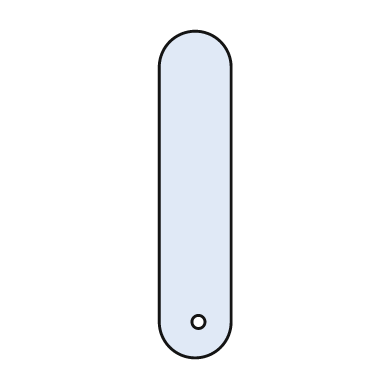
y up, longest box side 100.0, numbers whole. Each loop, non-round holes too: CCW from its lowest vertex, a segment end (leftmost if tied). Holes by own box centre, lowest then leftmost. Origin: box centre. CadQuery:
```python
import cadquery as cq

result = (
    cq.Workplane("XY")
    .moveTo(-11.0, -39.0)
    .threePointArc((0.0, -50.0), (11.0, -39.0))
    .lineTo(11.0, 39.0)
    .threePointArc((0.0, 50.0), (-11.0, 39.0))
    .close()
    .moveTo(1.0, -39.0)
    .circle(2.0)
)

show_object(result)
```